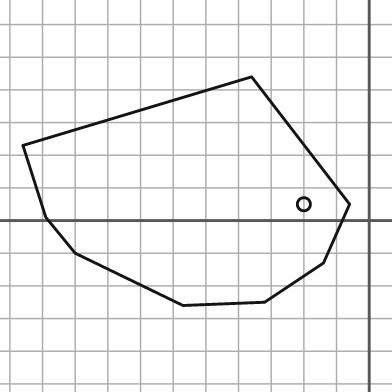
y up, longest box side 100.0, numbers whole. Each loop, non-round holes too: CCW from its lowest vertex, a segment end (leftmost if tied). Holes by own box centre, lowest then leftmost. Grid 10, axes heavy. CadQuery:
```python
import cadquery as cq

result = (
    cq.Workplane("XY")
    .moveTo(-57.0, -26.0)
    .lineTo(-32.0, -25.0)
    .lineTo(-14.0, -13.0)
    .lineTo(-6.0, 5.0)
    .lineTo(-36.0, 44.0)
    .lineTo(-106.0, 23.0)
    .lineTo(-99.0, 1.0)
    .lineTo(-90.0, -10.0)
    .close()
    .moveTo(-20.0, 5.0)
    .circle(2.0)
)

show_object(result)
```